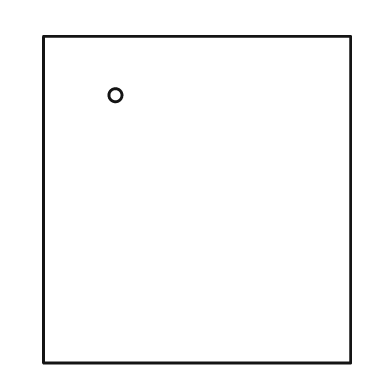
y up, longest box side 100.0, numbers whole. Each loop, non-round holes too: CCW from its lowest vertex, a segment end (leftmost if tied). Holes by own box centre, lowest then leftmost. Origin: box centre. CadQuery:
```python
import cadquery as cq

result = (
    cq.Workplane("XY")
    .moveTo(-47.0, -50.0)
    .lineTo(47.0, -50.0)
    .lineTo(47.0, 50.0)
    .lineTo(-47.0, 50.0)
    .close()
    .moveTo(-25.0, 32.0)
    .circle(2.0)
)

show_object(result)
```